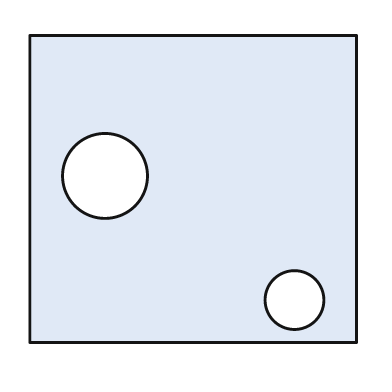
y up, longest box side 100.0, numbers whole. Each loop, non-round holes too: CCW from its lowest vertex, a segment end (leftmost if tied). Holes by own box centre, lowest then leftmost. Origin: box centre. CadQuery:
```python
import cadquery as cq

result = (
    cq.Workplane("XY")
    .moveTo(-50.0, -47.0)
    .lineTo(50.0, -47.0)
    .lineTo(50.0, 47.0)
    .lineTo(-50.0, 47.0)
    .close()
    .moveTo(31.0, -34.0)
    .circle(9.0)
    .moveTo(-27.0, 4.0)
    .circle(13.0)
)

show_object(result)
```